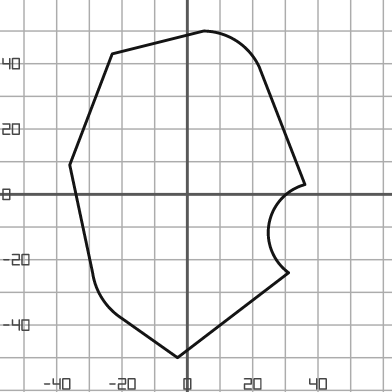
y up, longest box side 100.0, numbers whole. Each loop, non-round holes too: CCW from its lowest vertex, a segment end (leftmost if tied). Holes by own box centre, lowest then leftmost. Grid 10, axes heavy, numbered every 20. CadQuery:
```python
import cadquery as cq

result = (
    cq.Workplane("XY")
    .moveTo(-3.0, -50.0)
    .lineTo(31.0, -24.0)
    .threePointArc((25.0, -9.0), (36.0, 3.0))
    .lineTo(22.0, 39.0)
    .threePointArc((15.0, 47.0), (5.0, 50.0))
    .lineTo(-23.0, 43.0)
    .lineTo(-36.0, 9.0)
    .lineTo(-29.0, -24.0)
    .threePointArc((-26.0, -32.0), (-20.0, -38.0))
    .close()
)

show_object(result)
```